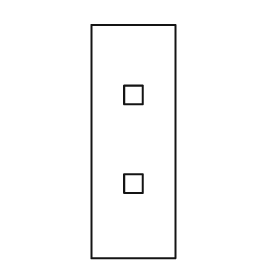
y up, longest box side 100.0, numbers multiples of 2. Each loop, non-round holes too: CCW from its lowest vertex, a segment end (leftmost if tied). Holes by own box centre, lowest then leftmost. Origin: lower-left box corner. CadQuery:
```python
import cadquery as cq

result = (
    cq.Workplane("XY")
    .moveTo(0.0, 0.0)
    .lineTo(36.0, 0.0)
    .lineTo(36.0, 100.0)
    .lineTo(0.0, 100.0)
    .close()
    .moveTo(14.0, 28.0)
    .lineTo(22.0, 28.0)
    .lineTo(22.0, 36.0)
    .lineTo(14.0, 36.0)
    .close()
    .moveTo(14.0, 66.0)
    .lineTo(22.0, 66.0)
    .lineTo(22.0, 74.0)
    .lineTo(14.0, 74.0)
    .close()
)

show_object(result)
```